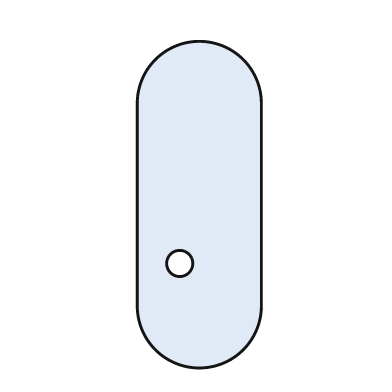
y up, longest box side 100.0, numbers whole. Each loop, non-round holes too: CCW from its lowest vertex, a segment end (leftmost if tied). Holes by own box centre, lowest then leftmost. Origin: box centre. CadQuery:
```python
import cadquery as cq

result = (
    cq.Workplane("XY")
    .moveTo(-19.0, -31.0)
    .threePointArc((0.0, -50.0), (19.0, -31.0))
    .lineTo(19.0, 31.0)
    .threePointArc((0.0, 50.0), (-19.0, 31.0))
    .close()
    .moveTo(-6.0, -18.0)
    .circle(4.0)
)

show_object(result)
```